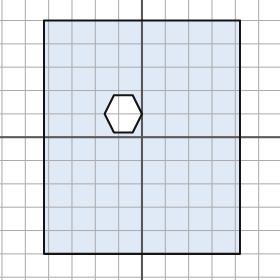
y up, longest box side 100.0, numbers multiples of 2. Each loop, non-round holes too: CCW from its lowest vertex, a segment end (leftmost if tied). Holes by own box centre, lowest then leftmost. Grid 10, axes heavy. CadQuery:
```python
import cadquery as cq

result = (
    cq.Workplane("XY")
    .moveTo(-42.0, -50.0)
    .lineTo(42.0, -50.0)
    .lineTo(42.0, 50.0)
    .lineTo(-42.0, 50.0)
    .close()
    .moveTo(-12.0, 2.0)
    .lineTo(-4.0, 2.0)
    .lineTo(0.0, 10.0)
    .lineTo(-4.0, 18.0)
    .lineTo(-12.0, 18.0)
    .lineTo(-16.0, 10.0)
    .close()
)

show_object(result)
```